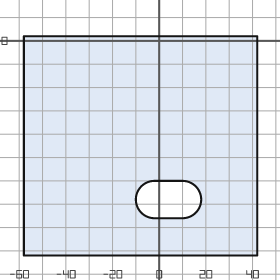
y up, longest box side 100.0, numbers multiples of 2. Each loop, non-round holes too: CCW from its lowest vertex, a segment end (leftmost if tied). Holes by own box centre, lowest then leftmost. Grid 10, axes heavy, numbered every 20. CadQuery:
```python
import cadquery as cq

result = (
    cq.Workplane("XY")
    .moveTo(-58.0, -92.0)
    .lineTo(42.0, -92.0)
    .lineTo(42.0, 2.0)
    .lineTo(-58.0, 2.0)
    .close()
    .moveTo(-2.0, -76.0)
    .lineTo(10.0, -76.0)
    .threePointArc((18.0, -68.0), (10.0, -60.0))
    .lineTo(-2.0, -60.0)
    .threePointArc((-10.0, -68.0), (-2.0, -76.0))
    .close()
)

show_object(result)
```